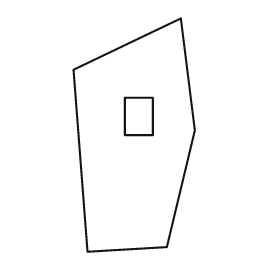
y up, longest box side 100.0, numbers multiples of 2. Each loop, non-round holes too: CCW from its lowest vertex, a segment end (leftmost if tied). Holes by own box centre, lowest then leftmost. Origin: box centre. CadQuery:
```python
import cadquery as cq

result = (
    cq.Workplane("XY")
    .moveTo(-20.0, -50.0)
    .lineTo(14.0, -48.0)
    .lineTo(26.0, 2.0)
    .lineTo(20.0, 50.0)
    .lineTo(-26.0, 28.0)
    .close()
    .moveTo(-4.0, 0.0)
    .lineTo(8.0, 0.0)
    .lineTo(8.0, 16.0)
    .lineTo(-4.0, 16.0)
    .close()
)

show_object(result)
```